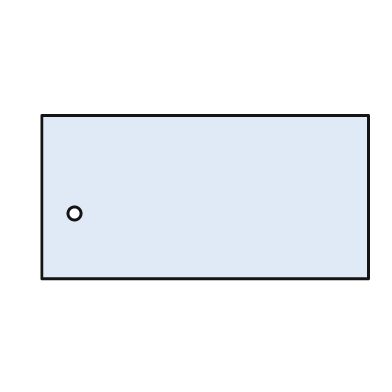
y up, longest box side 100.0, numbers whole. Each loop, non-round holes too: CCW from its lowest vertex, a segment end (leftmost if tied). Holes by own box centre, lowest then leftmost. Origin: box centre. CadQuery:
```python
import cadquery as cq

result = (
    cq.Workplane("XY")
    .moveTo(-50.0, -25.0)
    .lineTo(50.0, -25.0)
    .lineTo(50.0, 25.0)
    .lineTo(-50.0, 25.0)
    .close()
    .moveTo(-40.0, -5.0)
    .circle(2.0)
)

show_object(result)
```